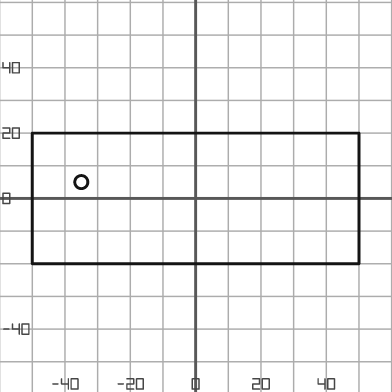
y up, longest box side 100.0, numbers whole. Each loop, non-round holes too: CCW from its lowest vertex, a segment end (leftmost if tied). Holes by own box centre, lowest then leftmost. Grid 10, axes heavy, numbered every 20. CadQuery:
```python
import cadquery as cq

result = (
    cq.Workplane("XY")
    .moveTo(-50.0, -20.0)
    .lineTo(50.0, -20.0)
    .lineTo(50.0, 20.0)
    .lineTo(-50.0, 20.0)
    .close()
    .moveTo(-35.0, 5.0)
    .circle(2.0)
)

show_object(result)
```